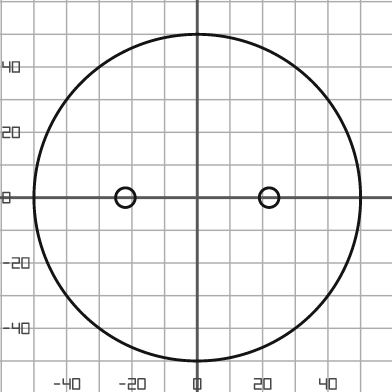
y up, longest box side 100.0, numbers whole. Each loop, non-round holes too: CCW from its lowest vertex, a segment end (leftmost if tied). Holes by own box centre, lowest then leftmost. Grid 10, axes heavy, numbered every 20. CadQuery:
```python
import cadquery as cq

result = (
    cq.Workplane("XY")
    .moveTo(0.0, 0.0)
    .circle(50.0)
    .moveTo(-22.0, 0.0)
    .circle(3.0)
    .moveTo(22.0, 0.0)
    .circle(3.0)
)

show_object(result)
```